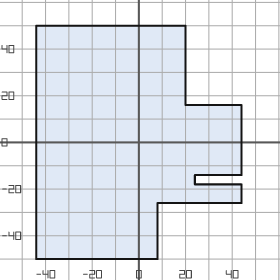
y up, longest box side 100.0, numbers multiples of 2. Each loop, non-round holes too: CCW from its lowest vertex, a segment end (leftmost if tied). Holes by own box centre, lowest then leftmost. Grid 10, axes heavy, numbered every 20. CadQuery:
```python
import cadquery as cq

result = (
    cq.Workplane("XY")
    .moveTo(-44.0, -50.0)
    .lineTo(8.0, -50.0)
    .lineTo(8.0, -26.0)
    .lineTo(44.0, -26.0)
    .lineTo(44.0, -18.0)
    .lineTo(24.0, -18.0)
    .lineTo(24.0, -14.0)
    .lineTo(44.0, -14.0)
    .lineTo(44.0, 16.0)
    .lineTo(20.0, 16.0)
    .lineTo(20.0, 50.0)
    .lineTo(-44.0, 50.0)
    .close()
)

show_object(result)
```